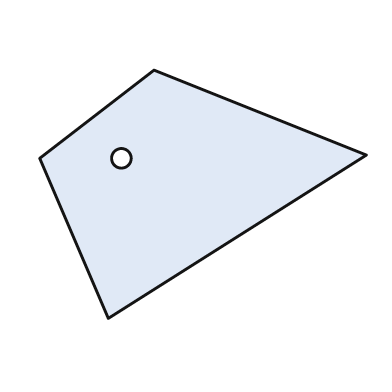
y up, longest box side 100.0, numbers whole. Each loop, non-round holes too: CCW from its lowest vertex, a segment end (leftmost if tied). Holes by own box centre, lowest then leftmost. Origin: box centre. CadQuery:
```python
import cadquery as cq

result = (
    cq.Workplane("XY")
    .moveTo(-29.0, -38.0)
    .lineTo(50.0, 12.0)
    .lineTo(-15.0, 38.0)
    .lineTo(-50.0, 11.0)
    .close()
    .moveTo(-25.0, 11.0)
    .circle(3.0)
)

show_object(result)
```